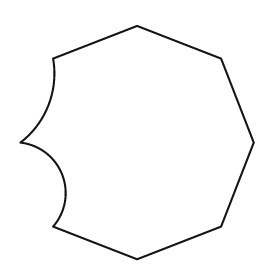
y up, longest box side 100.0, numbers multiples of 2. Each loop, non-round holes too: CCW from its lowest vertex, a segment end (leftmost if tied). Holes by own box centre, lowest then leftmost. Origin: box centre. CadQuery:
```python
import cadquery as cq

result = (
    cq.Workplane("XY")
    .moveTo(0.0, -50.0)
    .lineTo(36.0, -36.0)
    .lineTo(50.0, 0.0)
    .lineTo(36.0, 36.0)
    .lineTo(0.0, 50.0)
    .lineTo(-36.0, 36.0)
    .threePointArc((-38.0, 16.0), (-50.0, 0.0))
    .threePointArc((-32.0, -14.0), (-36.0, -36.0))
    .close()
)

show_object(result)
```